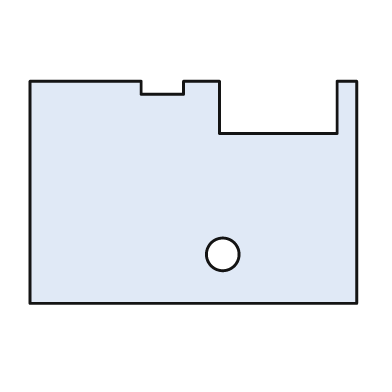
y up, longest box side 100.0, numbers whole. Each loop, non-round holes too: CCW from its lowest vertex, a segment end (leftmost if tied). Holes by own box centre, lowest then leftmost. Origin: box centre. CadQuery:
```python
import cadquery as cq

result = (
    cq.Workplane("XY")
    .moveTo(-50.0, -34.0)
    .lineTo(50.0, -34.0)
    .lineTo(50.0, 34.0)
    .lineTo(44.0, 34.0)
    .lineTo(44.0, 18.0)
    .lineTo(8.0, 18.0)
    .lineTo(8.0, 34.0)
    .lineTo(-3.0, 34.0)
    .lineTo(-3.0, 30.0)
    .lineTo(-16.0, 30.0)
    .lineTo(-16.0, 34.0)
    .lineTo(-50.0, 34.0)
    .close()
    .moveTo(9.0, -19.0)
    .circle(5.0)
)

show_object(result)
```